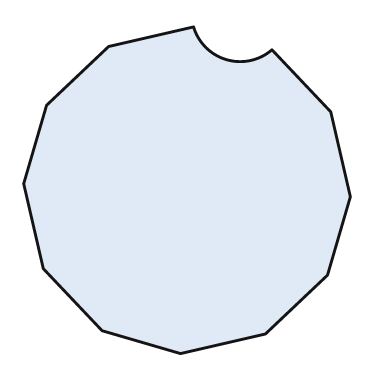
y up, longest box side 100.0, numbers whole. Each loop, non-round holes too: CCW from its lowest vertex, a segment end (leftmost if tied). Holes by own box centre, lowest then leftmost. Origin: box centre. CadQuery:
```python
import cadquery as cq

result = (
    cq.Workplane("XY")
    .moveTo(-2.0, -50.0)
    .lineTo(24.0, -44.0)
    .lineTo(43.0, -26.0)
    .lineTo(50.0, -2.0)
    .lineTo(44.0, 24.0)
    .lineTo(26.0, 43.0)
    .threePointArc((12.0, 40.0), (2.0, 50.0))
    .lineTo(-24.0, 44.0)
    .lineTo(-43.0, 26.0)
    .lineTo(-50.0, 2.0)
    .lineTo(-44.0, -24.0)
    .lineTo(-26.0, -43.0)
    .close()
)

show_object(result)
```